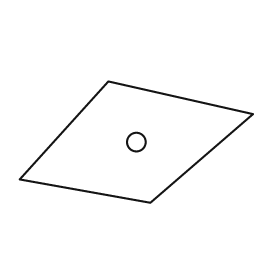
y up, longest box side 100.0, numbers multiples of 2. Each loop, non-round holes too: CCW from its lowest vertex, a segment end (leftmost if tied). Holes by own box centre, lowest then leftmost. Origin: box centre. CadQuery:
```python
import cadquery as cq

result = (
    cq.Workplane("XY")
    .moveTo(6.0, -26.0)
    .lineTo(50.0, 12.0)
    .lineTo(-12.0, 26.0)
    .lineTo(-50.0, -16.0)
    .close()
    .moveTo(0.0, 0.0)
    .circle(4.0)
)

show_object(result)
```